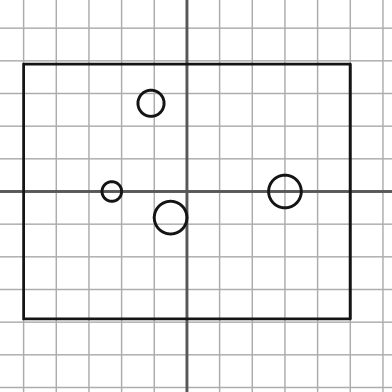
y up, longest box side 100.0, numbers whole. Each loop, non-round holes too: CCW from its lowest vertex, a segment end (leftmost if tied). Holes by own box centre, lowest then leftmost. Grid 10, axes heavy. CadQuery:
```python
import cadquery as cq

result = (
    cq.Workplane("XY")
    .moveTo(-50.0, -39.0)
    .lineTo(50.0, -39.0)
    .lineTo(50.0, 39.0)
    .lineTo(-50.0, 39.0)
    .close()
    .moveTo(-5.0, -8.0)
    .circle(5.0)
    .moveTo(-23.0, 0.0)
    .circle(3.0)
    .moveTo(30.0, 0.0)
    .circle(5.0)
    .moveTo(-11.0, 27.0)
    .circle(4.0)
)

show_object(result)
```